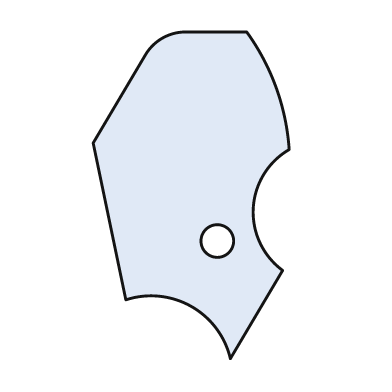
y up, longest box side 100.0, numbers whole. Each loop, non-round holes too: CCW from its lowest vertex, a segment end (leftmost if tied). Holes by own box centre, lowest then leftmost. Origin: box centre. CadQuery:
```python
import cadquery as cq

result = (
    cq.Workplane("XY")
    .moveTo(12.0, -50.0)
    .lineTo(28.0, -23.0)
    .threePointArc((19.0, -4.0), (30.0, 14.0))
    .threePointArc((26.0, 33.0), (17.0, 50.0))
    .lineTo(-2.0, 50.0)
    .threePointArc((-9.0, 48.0), (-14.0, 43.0))
    .lineTo(-30.0, 16.0)
    .lineTo(-20.0, -32.0)
    .threePointArc((0.0, -34.0), (12.0, -50.0))
    .close()
    .moveTo(8.0, -14.0)
    .circle(5.0)
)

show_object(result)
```